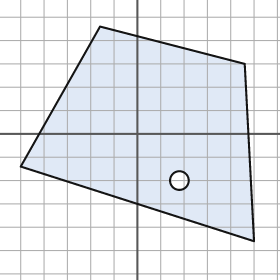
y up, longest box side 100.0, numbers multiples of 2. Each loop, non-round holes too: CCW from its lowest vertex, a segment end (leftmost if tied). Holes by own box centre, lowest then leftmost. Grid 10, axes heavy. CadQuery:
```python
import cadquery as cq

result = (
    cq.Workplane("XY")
    .moveTo(50.0, -46.0)
    .lineTo(46.0, 30.0)
    .lineTo(-16.0, 46.0)
    .lineTo(-50.0, -14.0)
    .close()
    .moveTo(18.0, -20.0)
    .circle(4.0)
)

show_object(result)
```